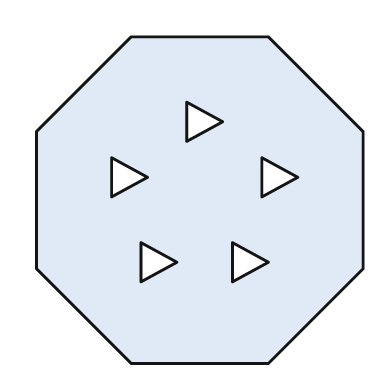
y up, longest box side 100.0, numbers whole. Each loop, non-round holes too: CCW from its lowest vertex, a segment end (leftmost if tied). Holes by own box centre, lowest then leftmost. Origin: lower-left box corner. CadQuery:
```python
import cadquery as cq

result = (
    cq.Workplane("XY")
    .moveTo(29.0, 0.0)
    .lineTo(71.0, 0.0)
    .lineTo(100.0, 29.0)
    .lineTo(100.0, 71.0)
    .lineTo(71.0, 100.0)
    .lineTo(29.0, 100.0)
    .lineTo(0.0, 71.0)
    .lineTo(0.0, 29.0)
    .close()
    .moveTo(32.0, 25.0)
    .lineTo(43.0, 31.0)
    .lineTo(32.0, 37.0)
    .close()
    .moveTo(60.0, 25.0)
    .lineTo(71.0, 31.0)
    .lineTo(60.0, 37.0)
    .close()
    .moveTo(23.0, 51.0)
    .lineTo(34.0, 57.0)
    .lineTo(23.0, 63.0)
    .close()
    .moveTo(69.0, 51.0)
    .lineTo(80.0, 57.0)
    .lineTo(69.0, 63.0)
    .close()
    .moveTo(46.0, 68.0)
    .lineTo(57.0, 74.0)
    .lineTo(46.0, 80.0)
    .close()
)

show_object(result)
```